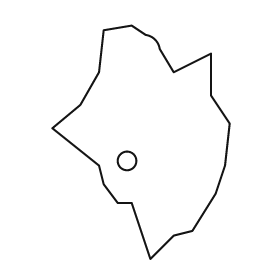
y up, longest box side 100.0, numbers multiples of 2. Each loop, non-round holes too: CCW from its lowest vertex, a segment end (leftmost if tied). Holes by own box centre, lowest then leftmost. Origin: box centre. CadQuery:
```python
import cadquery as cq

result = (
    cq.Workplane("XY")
    .moveTo(4.0, -50.0)
    .lineTo(14.0, -40.0)
    .lineTo(22.0, -38.0)
    .lineTo(32.0, -22.0)
    .lineTo(36.0, -10.0)
    .lineTo(38.0, 8.0)
    .lineTo(30.0, 20.0)
    .lineTo(30.0, 38.0)
    .lineTo(14.0, 30.0)
    .lineTo(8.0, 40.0)
    .threePointArc((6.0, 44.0), (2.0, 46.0))
    .lineTo(-4.0, 50.0)
    .lineTo(-16.0, 48.0)
    .lineTo(-18.0, 30.0)
    .lineTo(-26.0, 16.0)
    .lineTo(-38.0, 6.0)
    .lineTo(-18.0, -10.0)
    .lineTo(-16.0, -18.0)
    .lineTo(-10.0, -26.0)
    .lineTo(-4.0, -26.0)
    .close()
    .moveTo(-6.0, -8.0)
    .circle(4.0)
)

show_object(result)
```